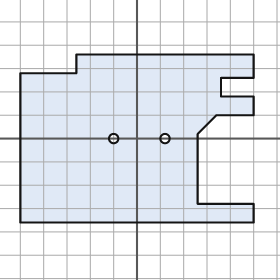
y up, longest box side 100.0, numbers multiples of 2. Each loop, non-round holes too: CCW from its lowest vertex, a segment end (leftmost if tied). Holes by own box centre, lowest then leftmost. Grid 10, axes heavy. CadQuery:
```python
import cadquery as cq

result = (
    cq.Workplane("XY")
    .moveTo(-50.0, -36.0)
    .lineTo(50.0, -36.0)
    .lineTo(50.0, -28.0)
    .lineTo(26.0, -28.0)
    .lineTo(26.0, 2.0)
    .lineTo(34.0, 10.0)
    .lineTo(50.0, 10.0)
    .lineTo(50.0, 18.0)
    .lineTo(36.0, 18.0)
    .lineTo(36.0, 26.0)
    .lineTo(50.0, 26.0)
    .lineTo(50.0, 36.0)
    .lineTo(-26.0, 36.0)
    .lineTo(-26.0, 28.0)
    .lineTo(-50.0, 28.0)
    .close()
    .moveTo(-10.0, 0.0)
    .circle(2.0)
    .moveTo(12.0, 0.0)
    .circle(2.0)
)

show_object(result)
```